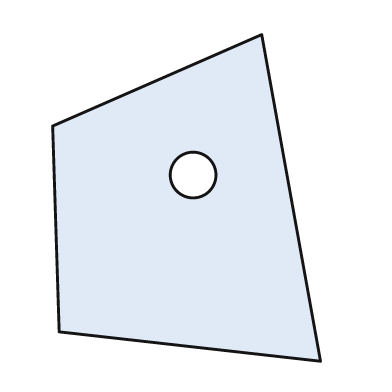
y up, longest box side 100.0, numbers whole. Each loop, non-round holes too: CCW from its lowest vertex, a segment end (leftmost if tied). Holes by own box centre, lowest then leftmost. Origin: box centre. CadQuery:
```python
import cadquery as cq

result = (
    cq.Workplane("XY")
    .moveTo(41.0, -50.0)
    .lineTo(23.0, 50.0)
    .lineTo(-41.0, 22.0)
    .lineTo(-39.0, -41.0)
    .close()
    .moveTo(2.0, 7.0)
    .circle(7.0)
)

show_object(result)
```